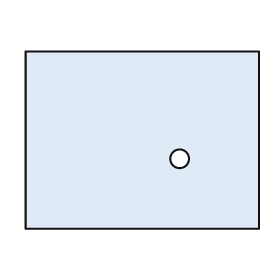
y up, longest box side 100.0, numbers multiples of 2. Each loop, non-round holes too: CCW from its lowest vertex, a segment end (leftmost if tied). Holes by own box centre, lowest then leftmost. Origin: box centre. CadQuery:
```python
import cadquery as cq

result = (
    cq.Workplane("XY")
    .moveTo(-50.0, -38.0)
    .lineTo(50.0, -38.0)
    .lineTo(50.0, 38.0)
    .lineTo(-50.0, 38.0)
    .close()
    .moveTo(16.0, -8.0)
    .circle(4.0)
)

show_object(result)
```